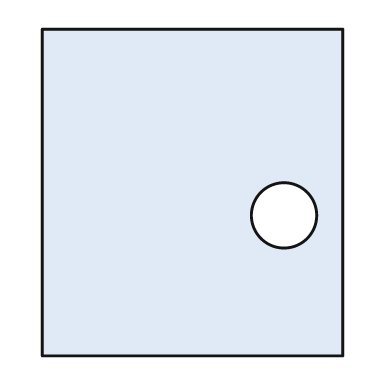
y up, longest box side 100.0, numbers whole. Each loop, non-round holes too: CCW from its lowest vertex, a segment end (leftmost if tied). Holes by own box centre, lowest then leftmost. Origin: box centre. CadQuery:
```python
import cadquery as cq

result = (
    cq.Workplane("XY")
    .moveTo(-46.0, -50.0)
    .lineTo(46.0, -50.0)
    .lineTo(46.0, 50.0)
    .lineTo(-46.0, 50.0)
    .close()
    .moveTo(28.0, -7.0)
    .circle(10.0)
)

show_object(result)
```